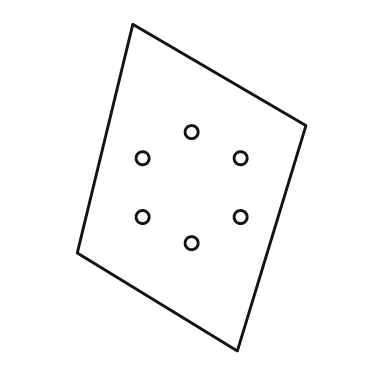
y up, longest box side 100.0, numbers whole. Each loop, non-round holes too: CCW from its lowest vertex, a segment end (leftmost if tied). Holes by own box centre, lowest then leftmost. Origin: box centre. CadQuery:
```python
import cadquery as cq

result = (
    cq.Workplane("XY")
    .moveTo(14.0, -50.0)
    .lineTo(35.0, 19.0)
    .lineTo(-18.0, 50.0)
    .lineTo(-35.0, -20.0)
    .close()
    .moveTo(0.0, -17.0)
    .circle(2.0)
    .moveTo(-15.0, -9.0)
    .circle(2.0)
    .moveTo(15.0, -9.0)
    .circle(2.0)
    .moveTo(-15.0, 9.0)
    .circle(2.0)
    .moveTo(15.0, 9.0)
    .circle(2.0)
    .moveTo(0.0, 17.0)
    .circle(2.0)
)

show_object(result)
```